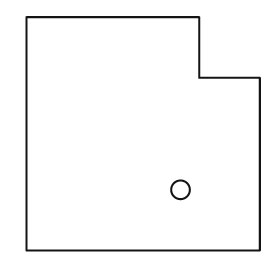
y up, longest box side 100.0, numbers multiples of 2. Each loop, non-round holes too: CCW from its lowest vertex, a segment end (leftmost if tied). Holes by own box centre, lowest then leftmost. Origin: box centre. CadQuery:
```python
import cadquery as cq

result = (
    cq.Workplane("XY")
    .moveTo(-50.0, -50.0)
    .lineTo(50.0, -50.0)
    .lineTo(50.0, 24.0)
    .lineTo(24.0, 24.0)
    .lineTo(24.0, 50.0)
    .lineTo(-50.0, 50.0)
    .close()
    .moveTo(16.0, -24.0)
    .circle(4.0)
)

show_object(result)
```